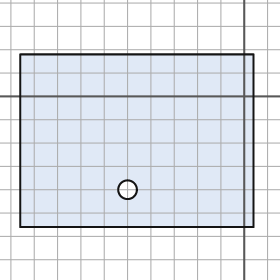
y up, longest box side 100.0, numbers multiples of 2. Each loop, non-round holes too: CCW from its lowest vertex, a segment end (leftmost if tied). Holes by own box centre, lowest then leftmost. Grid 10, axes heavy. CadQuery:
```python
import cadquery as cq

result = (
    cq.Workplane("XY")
    .moveTo(-96.0, -56.0)
    .lineTo(4.0, -56.0)
    .lineTo(4.0, 18.0)
    .lineTo(-96.0, 18.0)
    .close()
    .moveTo(-50.0, -40.0)
    .circle(4.0)
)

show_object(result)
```